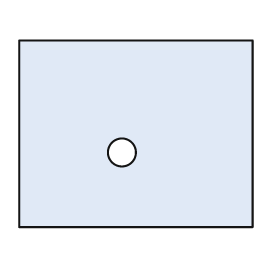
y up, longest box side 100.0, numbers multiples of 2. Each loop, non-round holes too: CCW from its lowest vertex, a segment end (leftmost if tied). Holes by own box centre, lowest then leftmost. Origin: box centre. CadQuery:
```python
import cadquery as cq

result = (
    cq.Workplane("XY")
    .moveTo(-50.0, -40.0)
    .lineTo(50.0, -40.0)
    .lineTo(50.0, 40.0)
    .lineTo(-50.0, 40.0)
    .close()
    .moveTo(-6.0, -8.0)
    .circle(6.0)
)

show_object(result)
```